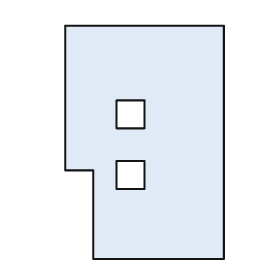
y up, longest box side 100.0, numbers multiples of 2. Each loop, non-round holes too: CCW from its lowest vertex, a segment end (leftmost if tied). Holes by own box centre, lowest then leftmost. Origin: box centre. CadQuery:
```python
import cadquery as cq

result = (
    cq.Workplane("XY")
    .moveTo(-22.0, -50.0)
    .lineTo(34.0, -50.0)
    .lineTo(34.0, 50.0)
    .lineTo(-34.0, 50.0)
    .lineTo(-34.0, -12.0)
    .lineTo(-22.0, -12.0)
    .close()
    .moveTo(-12.0, -20.0)
    .lineTo(0.0, -20.0)
    .lineTo(0.0, -8.0)
    .lineTo(-12.0, -8.0)
    .close()
    .moveTo(-12.0, 6.0)
    .lineTo(0.0, 6.0)
    .lineTo(0.0, 18.0)
    .lineTo(-12.0, 18.0)
    .close()
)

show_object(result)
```